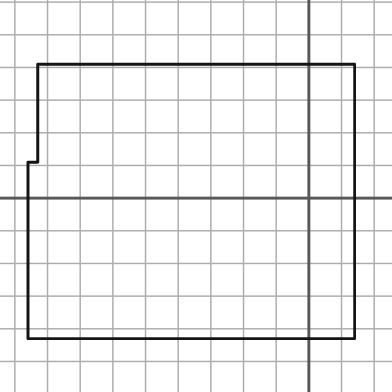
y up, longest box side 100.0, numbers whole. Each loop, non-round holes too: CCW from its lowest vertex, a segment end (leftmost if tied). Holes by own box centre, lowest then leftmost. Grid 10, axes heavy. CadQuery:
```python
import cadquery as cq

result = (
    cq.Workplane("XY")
    .moveTo(-86.0, -43.0)
    .lineTo(14.0, -43.0)
    .lineTo(14.0, 41.0)
    .lineTo(-83.0, 41.0)
    .lineTo(-83.0, 11.0)
    .lineTo(-86.0, 11.0)
    .close()
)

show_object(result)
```